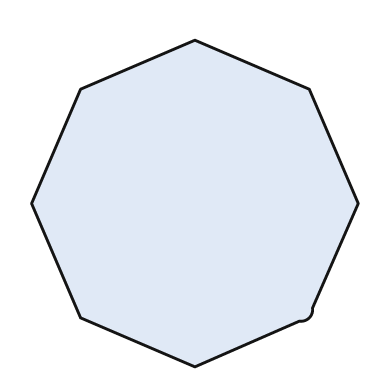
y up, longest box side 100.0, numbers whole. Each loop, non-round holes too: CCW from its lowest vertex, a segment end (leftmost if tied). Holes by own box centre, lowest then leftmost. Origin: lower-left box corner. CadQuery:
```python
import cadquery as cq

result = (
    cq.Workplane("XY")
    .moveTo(50.0, 0.0)
    .lineTo(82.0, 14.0)
    .threePointArc((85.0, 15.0), (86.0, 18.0))
    .lineTo(100.0, 50.0)
    .lineTo(85.0, 85.0)
    .lineTo(50.0, 100.0)
    .lineTo(15.0, 85.0)
    .lineTo(0.0, 50.0)
    .lineTo(15.0, 15.0)
    .close()
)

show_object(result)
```